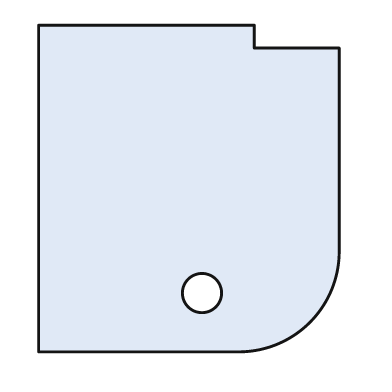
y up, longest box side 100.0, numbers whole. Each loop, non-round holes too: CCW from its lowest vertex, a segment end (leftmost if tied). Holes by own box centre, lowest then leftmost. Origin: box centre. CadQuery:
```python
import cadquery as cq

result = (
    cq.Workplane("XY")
    .moveTo(-46.0, -50.0)
    .lineTo(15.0, -50.0)
    .threePointArc((37.0, -41.0), (46.0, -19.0))
    .lineTo(46.0, 43.0)
    .lineTo(20.0, 43.0)
    .lineTo(20.0, 50.0)
    .lineTo(-46.0, 50.0)
    .close()
    .moveTo(4.0, -32.0)
    .circle(6.0)
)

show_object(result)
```